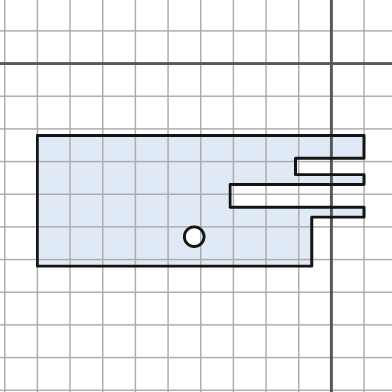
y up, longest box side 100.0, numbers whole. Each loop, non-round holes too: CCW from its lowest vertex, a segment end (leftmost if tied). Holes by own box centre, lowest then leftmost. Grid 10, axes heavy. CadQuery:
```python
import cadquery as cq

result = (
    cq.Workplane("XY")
    .moveTo(-90.0, -62.0)
    .lineTo(-6.0, -62.0)
    .lineTo(-6.0, -47.0)
    .lineTo(10.0, -47.0)
    .lineTo(10.0, -44.0)
    .lineTo(-31.0, -44.0)
    .lineTo(-31.0, -37.0)
    .lineTo(10.0, -37.0)
    .lineTo(10.0, -34.0)
    .lineTo(-11.0, -34.0)
    .lineTo(-11.0, -29.0)
    .lineTo(10.0, -29.0)
    .lineTo(10.0, -22.0)
    .lineTo(-90.0, -22.0)
    .close()
    .moveTo(-42.0, -53.0)
    .circle(3.0)
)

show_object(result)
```